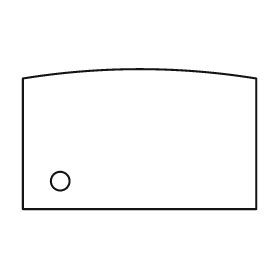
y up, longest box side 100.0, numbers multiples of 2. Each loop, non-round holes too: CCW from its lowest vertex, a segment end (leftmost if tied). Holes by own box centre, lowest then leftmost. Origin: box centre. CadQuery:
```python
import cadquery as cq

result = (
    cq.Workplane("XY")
    .moveTo(-50.0, -30.0)
    .lineTo(50.0, -30.0)
    .lineTo(50.0, 26.0)
    .threePointArc((0.0, 30.0), (-50.0, 26.0))
    .close()
    .moveTo(-34.0, -18.0)
    .circle(4.0)
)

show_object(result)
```